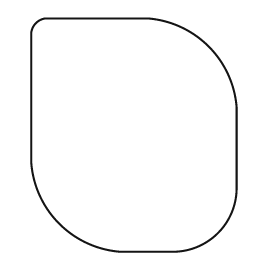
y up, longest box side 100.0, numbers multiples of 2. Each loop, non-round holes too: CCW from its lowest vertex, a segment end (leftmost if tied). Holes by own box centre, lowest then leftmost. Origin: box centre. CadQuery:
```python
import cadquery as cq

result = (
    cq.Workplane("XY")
    .moveTo(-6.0, -50.0)
    .lineTo(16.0, -50.0)
    .threePointArc((36.0, -42.0), (44.0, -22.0))
    .lineTo(44.0, 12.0)
    .threePointArc((32.0, 38.0), (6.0, 50.0))
    .lineTo(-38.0, 50.0)
    .threePointArc((-42.0, 48.0), (-44.0, 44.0))
    .lineTo(-44.0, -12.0)
    .threePointArc((-32.0, -38.0), (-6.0, -50.0))
    .close()
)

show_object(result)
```